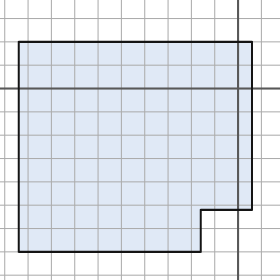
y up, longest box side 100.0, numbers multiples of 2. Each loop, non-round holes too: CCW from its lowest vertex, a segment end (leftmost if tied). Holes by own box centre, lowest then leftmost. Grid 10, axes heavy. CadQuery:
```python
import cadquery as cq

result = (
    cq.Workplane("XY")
    .moveTo(-94.0, -70.0)
    .lineTo(-16.0, -70.0)
    .lineTo(-16.0, -52.0)
    .lineTo(6.0, -52.0)
    .lineTo(6.0, 20.0)
    .lineTo(-94.0, 20.0)
    .close()
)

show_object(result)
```